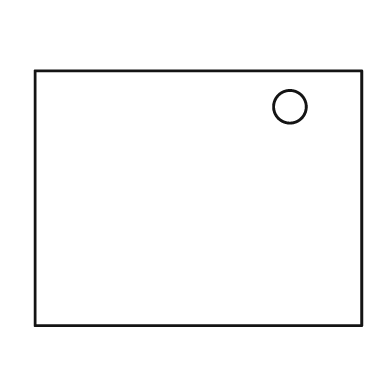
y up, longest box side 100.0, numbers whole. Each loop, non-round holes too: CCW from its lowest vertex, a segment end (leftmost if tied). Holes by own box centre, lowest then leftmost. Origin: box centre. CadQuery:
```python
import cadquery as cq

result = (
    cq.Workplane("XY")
    .moveTo(-50.0, -39.0)
    .lineTo(50.0, -39.0)
    .lineTo(50.0, 39.0)
    .lineTo(-50.0, 39.0)
    .close()
    .moveTo(28.0, 28.0)
    .circle(5.0)
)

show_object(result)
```